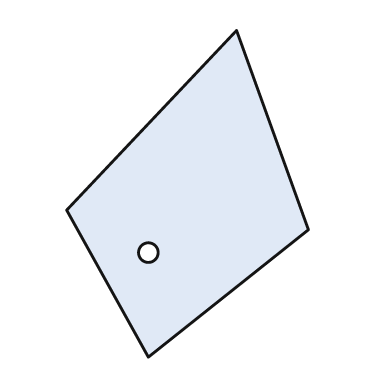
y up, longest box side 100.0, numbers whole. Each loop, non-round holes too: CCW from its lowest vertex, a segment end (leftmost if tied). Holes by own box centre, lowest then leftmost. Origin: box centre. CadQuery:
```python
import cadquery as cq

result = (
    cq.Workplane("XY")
    .moveTo(-12.0, -50.0)
    .lineTo(37.0, -11.0)
    .lineTo(15.0, 50.0)
    .lineTo(-37.0, -5.0)
    .close()
    .moveTo(-12.0, -18.0)
    .circle(3.0)
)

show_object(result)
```